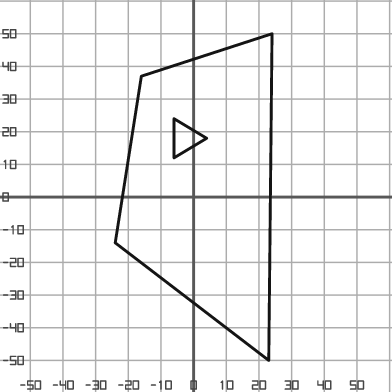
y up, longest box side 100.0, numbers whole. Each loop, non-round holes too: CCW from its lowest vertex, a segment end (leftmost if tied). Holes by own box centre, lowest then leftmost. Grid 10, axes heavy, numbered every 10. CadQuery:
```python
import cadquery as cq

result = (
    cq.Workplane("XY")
    .moveTo(23.0, -50.0)
    .lineTo(24.0, 50.0)
    .lineTo(-16.0, 37.0)
    .lineTo(-24.0, -14.0)
    .close()
    .moveTo(-6.0, 12.0)
    .lineTo(4.0, 18.0)
    .lineTo(-6.0, 24.0)
    .close()
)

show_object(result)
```